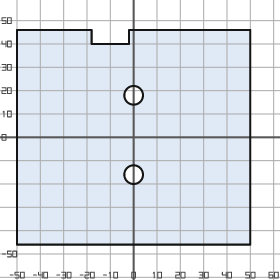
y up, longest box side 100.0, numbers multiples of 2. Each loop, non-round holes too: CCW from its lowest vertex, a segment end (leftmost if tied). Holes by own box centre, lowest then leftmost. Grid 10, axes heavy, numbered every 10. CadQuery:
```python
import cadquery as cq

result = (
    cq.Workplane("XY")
    .moveTo(-50.0, -46.0)
    .lineTo(50.0, -46.0)
    .lineTo(50.0, 46.0)
    .lineTo(-2.0, 46.0)
    .lineTo(-2.0, 40.0)
    .lineTo(-18.0, 40.0)
    .lineTo(-18.0, 46.0)
    .lineTo(-50.0, 46.0)
    .close()
    .moveTo(0.0, -16.0)
    .circle(4.0)
    .moveTo(0.0, 18.0)
    .circle(4.0)
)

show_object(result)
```